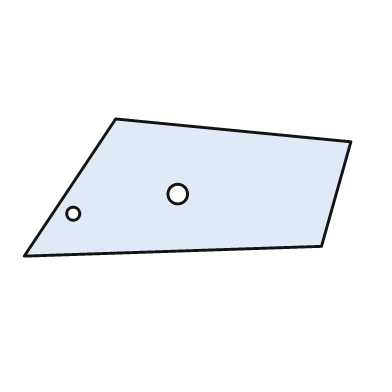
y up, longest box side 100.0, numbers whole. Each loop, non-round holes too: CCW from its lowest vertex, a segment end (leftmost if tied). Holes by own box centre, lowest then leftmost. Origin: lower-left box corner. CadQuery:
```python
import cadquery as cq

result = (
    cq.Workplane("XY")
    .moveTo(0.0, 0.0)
    .lineTo(91.0, 3.0)
    .lineTo(100.0, 35.0)
    .lineTo(28.0, 42.0)
    .close()
    .moveTo(15.0, 13.0)
    .circle(2.0)
    .moveTo(47.0, 19.0)
    .circle(3.0)
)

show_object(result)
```